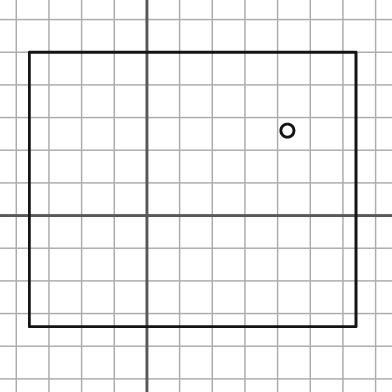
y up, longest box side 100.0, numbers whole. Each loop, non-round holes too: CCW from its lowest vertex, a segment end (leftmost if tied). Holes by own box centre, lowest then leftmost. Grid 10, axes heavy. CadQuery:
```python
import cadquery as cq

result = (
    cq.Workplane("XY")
    .moveTo(-36.0, -34.0)
    .lineTo(64.0, -34.0)
    .lineTo(64.0, 50.0)
    .lineTo(-36.0, 50.0)
    .close()
    .moveTo(43.0, 26.0)
    .circle(2.0)
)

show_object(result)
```